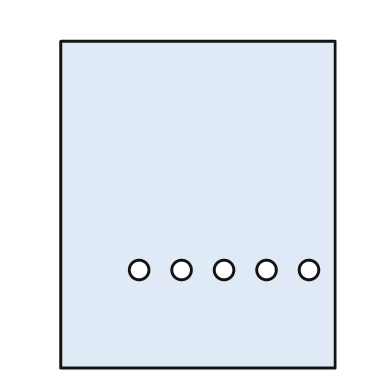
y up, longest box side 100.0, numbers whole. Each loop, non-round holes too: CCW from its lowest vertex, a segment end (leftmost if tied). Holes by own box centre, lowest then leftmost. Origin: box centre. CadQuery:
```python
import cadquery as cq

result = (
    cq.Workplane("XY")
    .moveTo(-42.0, -50.0)
    .lineTo(42.0, -50.0)
    .lineTo(42.0, 50.0)
    .lineTo(-42.0, 50.0)
    .close()
    .moveTo(-18.0, -20.0)
    .circle(3.0)
    .moveTo(-5.0, -20.0)
    .circle(3.0)
    .moveTo(8.0, -20.0)
    .circle(3.0)
    .moveTo(21.0, -20.0)
    .circle(3.0)
    .moveTo(34.0, -20.0)
    .circle(3.0)
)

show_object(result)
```